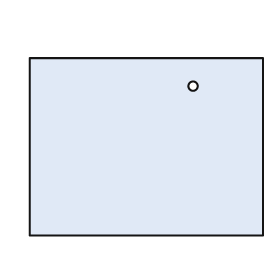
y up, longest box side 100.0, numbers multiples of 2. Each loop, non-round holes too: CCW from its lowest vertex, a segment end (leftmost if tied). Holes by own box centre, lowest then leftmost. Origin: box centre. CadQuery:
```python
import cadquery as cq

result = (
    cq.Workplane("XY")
    .moveTo(-50.0, -38.0)
    .lineTo(50.0, -38.0)
    .lineTo(50.0, 38.0)
    .lineTo(-50.0, 38.0)
    .close()
    .moveTo(20.0, 26.0)
    .circle(2.0)
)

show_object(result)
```